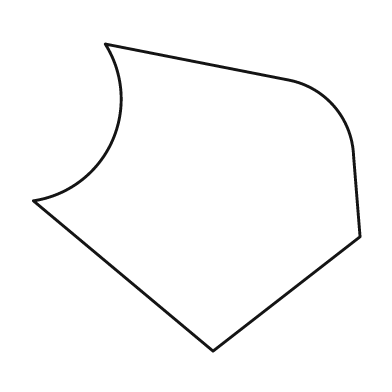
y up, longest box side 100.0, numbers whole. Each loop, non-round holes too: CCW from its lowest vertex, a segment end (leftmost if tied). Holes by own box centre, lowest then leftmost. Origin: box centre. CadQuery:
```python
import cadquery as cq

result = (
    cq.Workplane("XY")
    .moveTo(5.0, -47.0)
    .lineTo(50.0, -12.0)
    .lineTo(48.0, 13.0)
    .threePointArc((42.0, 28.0), (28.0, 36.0))
    .lineTo(-28.0, 47.0)
    .threePointArc((-26.0, 17.0), (-50.0, -1.0))
    .close()
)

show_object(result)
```